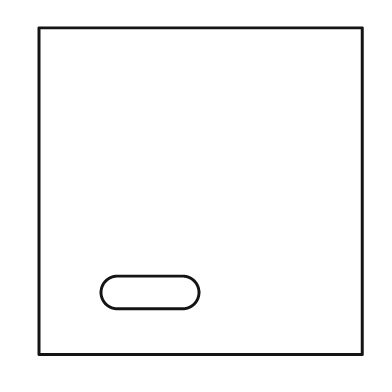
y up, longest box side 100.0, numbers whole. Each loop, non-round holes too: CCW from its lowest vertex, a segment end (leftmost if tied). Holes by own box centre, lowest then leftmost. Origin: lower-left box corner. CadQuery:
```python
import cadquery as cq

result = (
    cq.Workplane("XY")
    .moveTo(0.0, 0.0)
    .lineTo(99.0, 0.0)
    .lineTo(99.0, 100.0)
    .lineTo(0.0, 100.0)
    .close()
    .moveTo(24.0, 14.0)
    .lineTo(44.0, 14.0)
    .threePointArc((49.0, 19.0), (44.0, 24.0))
    .lineTo(24.0, 24.0)
    .threePointArc((19.0, 19.0), (24.0, 14.0))
    .close()
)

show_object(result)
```